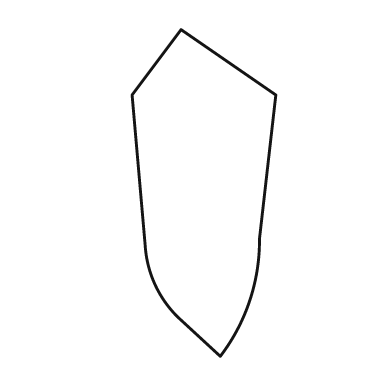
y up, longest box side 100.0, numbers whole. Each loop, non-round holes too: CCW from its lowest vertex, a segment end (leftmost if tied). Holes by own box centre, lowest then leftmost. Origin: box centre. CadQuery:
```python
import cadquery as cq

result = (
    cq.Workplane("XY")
    .moveTo(5.0, -50.0)
    .threePointArc((14.0, -33.0), (17.0, -14.0))
    .lineTo(22.0, 30.0)
    .lineTo(-7.0, 50.0)
    .lineTo(-22.0, 30.0)
    .lineTo(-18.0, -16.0)
    .threePointArc((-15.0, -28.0), (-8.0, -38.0))
    .close()
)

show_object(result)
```